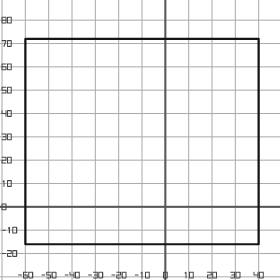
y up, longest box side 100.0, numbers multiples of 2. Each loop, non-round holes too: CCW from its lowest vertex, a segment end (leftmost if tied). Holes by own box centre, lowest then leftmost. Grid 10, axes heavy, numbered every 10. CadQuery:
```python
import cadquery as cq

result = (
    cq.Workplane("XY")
    .moveTo(-60.0, -16.0)
    .lineTo(40.0, -16.0)
    .lineTo(40.0, 72.0)
    .lineTo(-60.0, 72.0)
    .close()
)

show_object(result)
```